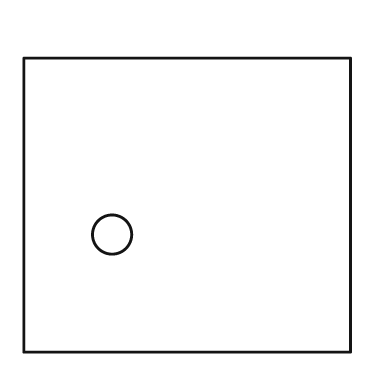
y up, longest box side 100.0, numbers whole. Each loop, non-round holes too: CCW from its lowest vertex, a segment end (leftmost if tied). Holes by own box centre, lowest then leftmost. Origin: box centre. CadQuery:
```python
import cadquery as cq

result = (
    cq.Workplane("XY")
    .moveTo(-50.0, -45.0)
    .lineTo(50.0, -45.0)
    .lineTo(50.0, 45.0)
    .lineTo(-50.0, 45.0)
    .close()
    .moveTo(-23.0, -9.0)
    .circle(6.0)
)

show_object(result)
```